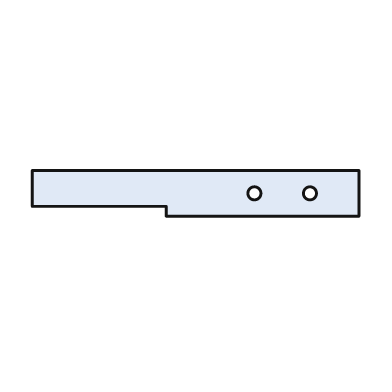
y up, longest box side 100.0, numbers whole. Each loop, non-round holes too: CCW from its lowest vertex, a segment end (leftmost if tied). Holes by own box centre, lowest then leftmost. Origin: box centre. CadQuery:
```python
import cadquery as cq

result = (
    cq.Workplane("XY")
    .moveTo(-9.0, -7.0)
    .lineTo(50.0, -7.0)
    .lineTo(50.0, 7.0)
    .lineTo(-50.0, 7.0)
    .lineTo(-50.0, -4.0)
    .lineTo(-9.0, -4.0)
    .close()
    .moveTo(18.0, 0.0)
    .circle(2.0)
    .moveTo(35.0, 0.0)
    .circle(2.0)
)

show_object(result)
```